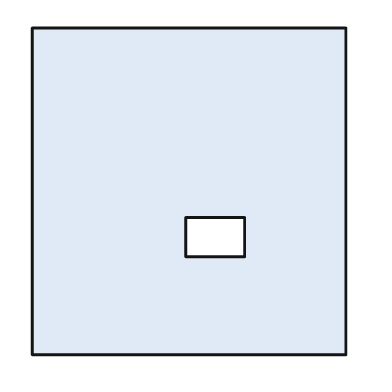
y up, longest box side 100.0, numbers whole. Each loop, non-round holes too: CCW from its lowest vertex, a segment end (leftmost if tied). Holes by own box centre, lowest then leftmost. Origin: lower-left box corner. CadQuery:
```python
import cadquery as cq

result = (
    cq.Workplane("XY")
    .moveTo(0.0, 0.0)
    .lineTo(96.0, 0.0)
    .lineTo(96.0, 100.0)
    .lineTo(0.0, 100.0)
    .close()
    .moveTo(47.0, 30.0)
    .lineTo(65.0, 30.0)
    .lineTo(65.0, 42.0)
    .lineTo(47.0, 42.0)
    .close()
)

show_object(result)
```